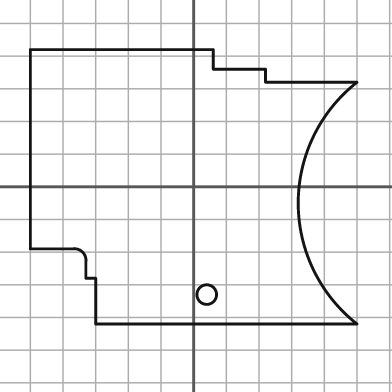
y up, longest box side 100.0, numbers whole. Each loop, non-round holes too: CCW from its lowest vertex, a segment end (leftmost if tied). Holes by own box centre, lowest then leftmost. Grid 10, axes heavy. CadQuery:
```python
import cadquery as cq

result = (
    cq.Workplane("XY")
    .moveTo(-30.0, -42.0)
    .lineTo(50.0, -42.0)
    .threePointArc((32.0, -5.0), (50.0, 32.0))
    .lineTo(22.0, 32.0)
    .lineTo(22.0, 36.0)
    .lineTo(6.0, 36.0)
    .lineTo(6.0, 42.0)
    .lineTo(-50.0, 42.0)
    .lineTo(-50.0, -19.0)
    .lineTo(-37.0, -19.0)
    .threePointArc((-34.0, -20.0), (-33.0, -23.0))
    .lineTo(-33.0, -28.0)
    .lineTo(-30.0, -28.0)
    .close()
    .moveTo(4.0, -33.0)
    .circle(3.0)
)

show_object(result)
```